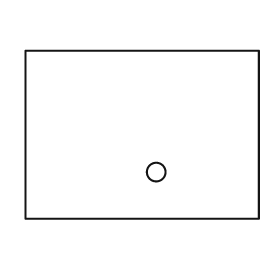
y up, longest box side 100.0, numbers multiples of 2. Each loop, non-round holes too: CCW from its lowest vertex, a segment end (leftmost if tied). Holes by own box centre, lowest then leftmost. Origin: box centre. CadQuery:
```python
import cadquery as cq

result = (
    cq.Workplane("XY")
    .moveTo(-50.0, -36.0)
    .lineTo(50.0, -36.0)
    .lineTo(50.0, 36.0)
    .lineTo(-50.0, 36.0)
    .close()
    .moveTo(6.0, -16.0)
    .circle(4.0)
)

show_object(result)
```